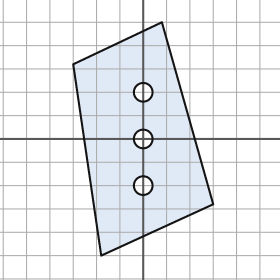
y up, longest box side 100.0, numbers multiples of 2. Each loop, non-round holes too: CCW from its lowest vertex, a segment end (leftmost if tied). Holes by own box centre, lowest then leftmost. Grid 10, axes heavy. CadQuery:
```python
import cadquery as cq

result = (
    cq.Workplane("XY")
    .moveTo(-18.0, -50.0)
    .lineTo(30.0, -28.0)
    .lineTo(8.0, 50.0)
    .lineTo(-30.0, 32.0)
    .close()
    .moveTo(0.0, -20.0)
    .circle(4.0)
    .moveTo(0.0, 0.0)
    .circle(4.0)
    .moveTo(0.0, 20.0)
    .circle(4.0)
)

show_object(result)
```